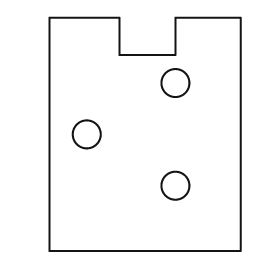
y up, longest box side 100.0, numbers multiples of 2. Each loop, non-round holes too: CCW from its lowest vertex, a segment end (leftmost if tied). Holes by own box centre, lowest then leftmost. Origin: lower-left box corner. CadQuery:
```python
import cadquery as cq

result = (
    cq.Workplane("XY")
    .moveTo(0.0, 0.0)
    .lineTo(82.0, 0.0)
    .lineTo(82.0, 100.0)
    .lineTo(54.0, 100.0)
    .lineTo(54.0, 84.0)
    .lineTo(30.0, 84.0)
    .lineTo(30.0, 100.0)
    .lineTo(0.0, 100.0)
    .close()
    .moveTo(54.0, 28.0)
    .circle(6.0)
    .moveTo(16.0, 50.0)
    .circle(6.0)
    .moveTo(54.0, 72.0)
    .circle(6.0)
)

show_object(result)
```